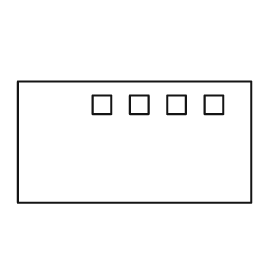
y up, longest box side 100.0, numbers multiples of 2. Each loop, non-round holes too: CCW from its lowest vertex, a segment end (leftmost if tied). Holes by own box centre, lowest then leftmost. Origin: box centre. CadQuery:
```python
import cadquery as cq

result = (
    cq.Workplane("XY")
    .moveTo(-50.0, -26.0)
    .lineTo(50.0, -26.0)
    .lineTo(50.0, 26.0)
    .lineTo(-50.0, 26.0)
    .close()
    .moveTo(-18.0, 12.0)
    .lineTo(-10.0, 12.0)
    .lineTo(-10.0, 20.0)
    .lineTo(-18.0, 20.0)
    .close()
    .moveTo(-2.0, 12.0)
    .lineTo(6.0, 12.0)
    .lineTo(6.0, 20.0)
    .lineTo(-2.0, 20.0)
    .close()
    .moveTo(14.0, 12.0)
    .lineTo(22.0, 12.0)
    .lineTo(22.0, 20.0)
    .lineTo(14.0, 20.0)
    .close()
    .moveTo(30.0, 12.0)
    .lineTo(38.0, 12.0)
    .lineTo(38.0, 20.0)
    .lineTo(30.0, 20.0)
    .close()
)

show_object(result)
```